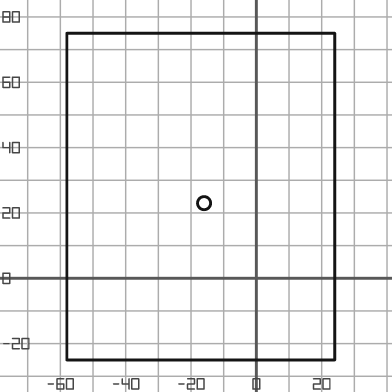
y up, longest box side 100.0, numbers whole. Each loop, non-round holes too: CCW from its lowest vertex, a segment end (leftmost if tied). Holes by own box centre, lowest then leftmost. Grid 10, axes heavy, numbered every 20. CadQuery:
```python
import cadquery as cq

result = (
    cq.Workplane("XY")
    .moveTo(-58.0, -25.0)
    .lineTo(24.0, -25.0)
    .lineTo(24.0, 75.0)
    .lineTo(-58.0, 75.0)
    .close()
    .moveTo(-16.0, 23.0)
    .circle(2.0)
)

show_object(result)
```